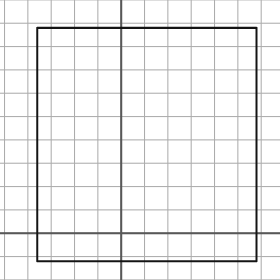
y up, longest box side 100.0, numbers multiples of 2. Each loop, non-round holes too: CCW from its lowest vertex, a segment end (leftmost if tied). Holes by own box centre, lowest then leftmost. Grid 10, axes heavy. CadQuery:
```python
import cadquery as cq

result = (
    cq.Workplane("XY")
    .moveTo(-36.0, -12.0)
    .lineTo(58.0, -12.0)
    .lineTo(58.0, 88.0)
    .lineTo(-36.0, 88.0)
    .close()
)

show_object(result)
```